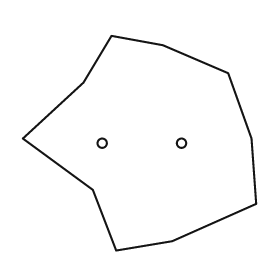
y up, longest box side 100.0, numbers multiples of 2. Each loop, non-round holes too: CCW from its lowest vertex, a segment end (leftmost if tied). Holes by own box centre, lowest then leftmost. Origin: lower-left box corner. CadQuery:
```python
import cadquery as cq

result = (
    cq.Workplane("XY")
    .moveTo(40.0, 0.0)
    .lineTo(64.0, 4.0)
    .lineTo(100.0, 20.0)
    .lineTo(98.0, 48.0)
    .lineTo(88.0, 76.0)
    .lineTo(60.0, 88.0)
    .lineTo(38.0, 92.0)
    .lineTo(26.0, 72.0)
    .lineTo(0.0, 48.0)
    .lineTo(30.0, 26.0)
    .close()
    .moveTo(34.0, 46.0)
    .circle(2.0)
    .moveTo(68.0, 46.0)
    .circle(2.0)
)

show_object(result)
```